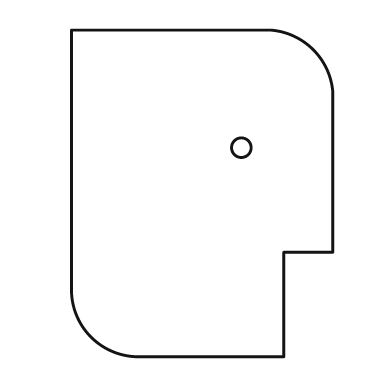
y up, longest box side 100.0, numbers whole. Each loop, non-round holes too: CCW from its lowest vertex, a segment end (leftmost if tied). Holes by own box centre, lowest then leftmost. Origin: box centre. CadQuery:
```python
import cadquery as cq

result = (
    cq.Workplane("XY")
    .moveTo(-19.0, -50.0)
    .lineTo(25.0, -50.0)
    .lineTo(25.0, -18.0)
    .lineTo(40.0, -18.0)
    .lineTo(40.0, 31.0)
    .threePointArc((34.0, 44.0), (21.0, 50.0))
    .lineTo(-40.0, 50.0)
    .lineTo(-40.0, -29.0)
    .threePointArc((-34.0, -44.0), (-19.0, -50.0))
    .close()
    .moveTo(12.0, 14.0)
    .circle(3.0)
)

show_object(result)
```